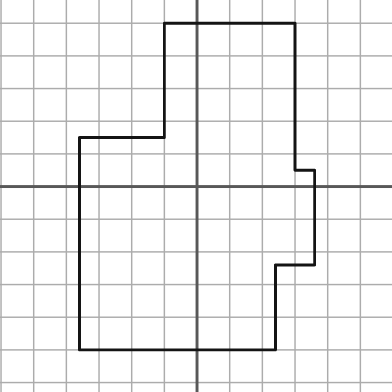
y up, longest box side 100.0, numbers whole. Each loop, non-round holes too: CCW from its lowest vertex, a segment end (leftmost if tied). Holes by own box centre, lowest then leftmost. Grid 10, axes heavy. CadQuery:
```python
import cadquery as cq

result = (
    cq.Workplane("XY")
    .moveTo(-36.0, -50.0)
    .lineTo(24.0, -50.0)
    .lineTo(24.0, -24.0)
    .lineTo(36.0, -24.0)
    .lineTo(36.0, 5.0)
    .lineTo(30.0, 5.0)
    .lineTo(30.0, 50.0)
    .lineTo(-10.0, 50.0)
    .lineTo(-10.0, 15.0)
    .lineTo(-36.0, 15.0)
    .close()
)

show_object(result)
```